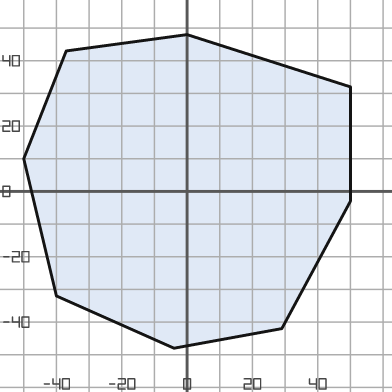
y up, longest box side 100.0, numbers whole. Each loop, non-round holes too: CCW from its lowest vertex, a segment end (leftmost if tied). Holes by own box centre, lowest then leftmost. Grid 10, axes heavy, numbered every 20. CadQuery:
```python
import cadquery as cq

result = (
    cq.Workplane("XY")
    .moveTo(-4.0, -48.0)
    .lineTo(29.0, -42.0)
    .lineTo(50.0, -3.0)
    .lineTo(50.0, 32.0)
    .lineTo(0.0, 48.0)
    .lineTo(-37.0, 43.0)
    .lineTo(-50.0, 10.0)
    .lineTo(-40.0, -32.0)
    .close()
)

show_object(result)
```